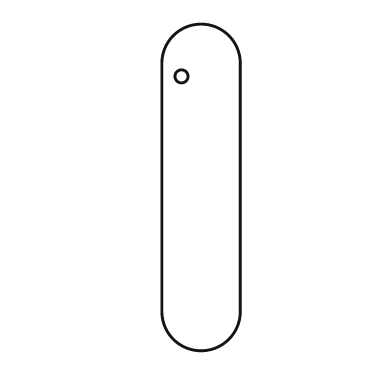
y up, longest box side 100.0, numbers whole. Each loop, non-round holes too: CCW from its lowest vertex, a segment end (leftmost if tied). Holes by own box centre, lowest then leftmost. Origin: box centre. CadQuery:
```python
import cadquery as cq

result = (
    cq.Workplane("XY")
    .moveTo(-12.0, -38.0)
    .threePointArc((0.0, -50.0), (12.0, -38.0))
    .lineTo(12.0, 38.0)
    .threePointArc((0.0, 50.0), (-12.0, 38.0))
    .close()
    .moveTo(-6.0, 34.0)
    .circle(2.0)
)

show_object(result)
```